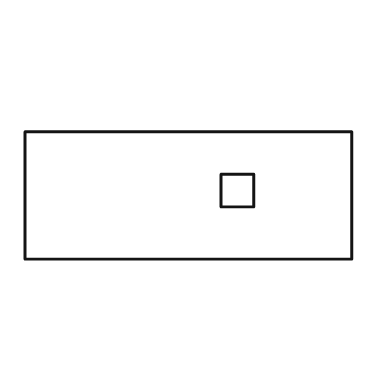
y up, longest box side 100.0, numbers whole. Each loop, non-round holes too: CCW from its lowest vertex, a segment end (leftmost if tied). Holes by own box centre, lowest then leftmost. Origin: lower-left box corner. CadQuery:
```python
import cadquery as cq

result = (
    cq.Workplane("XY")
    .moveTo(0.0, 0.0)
    .lineTo(100.0, 0.0)
    .lineTo(100.0, 39.0)
    .lineTo(0.0, 39.0)
    .close()
    .moveTo(60.0, 16.0)
    .lineTo(70.0, 16.0)
    .lineTo(70.0, 26.0)
    .lineTo(60.0, 26.0)
    .close()
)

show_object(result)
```